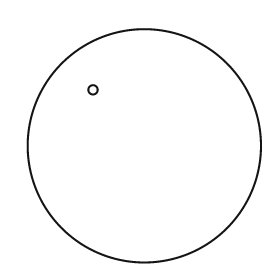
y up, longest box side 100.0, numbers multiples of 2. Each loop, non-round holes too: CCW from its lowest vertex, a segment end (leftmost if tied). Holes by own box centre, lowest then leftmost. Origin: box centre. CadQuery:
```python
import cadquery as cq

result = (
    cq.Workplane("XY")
    .moveTo(0.0, 0.0)
    .circle(50.0)
    .moveTo(-22.0, 24.0)
    .circle(2.0)
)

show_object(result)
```